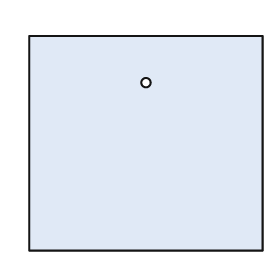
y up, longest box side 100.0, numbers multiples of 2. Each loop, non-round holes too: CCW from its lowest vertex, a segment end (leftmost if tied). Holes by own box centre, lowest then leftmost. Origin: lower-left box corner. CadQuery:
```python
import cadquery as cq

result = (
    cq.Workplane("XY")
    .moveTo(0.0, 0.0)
    .lineTo(100.0, 0.0)
    .lineTo(100.0, 92.0)
    .lineTo(0.0, 92.0)
    .close()
    .moveTo(50.0, 72.0)
    .circle(2.0)
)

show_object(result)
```